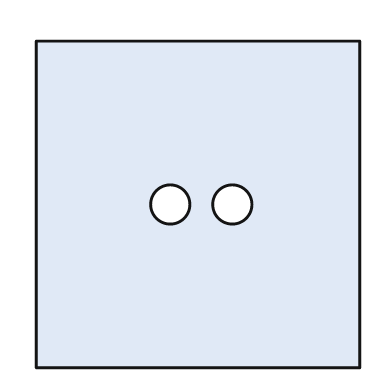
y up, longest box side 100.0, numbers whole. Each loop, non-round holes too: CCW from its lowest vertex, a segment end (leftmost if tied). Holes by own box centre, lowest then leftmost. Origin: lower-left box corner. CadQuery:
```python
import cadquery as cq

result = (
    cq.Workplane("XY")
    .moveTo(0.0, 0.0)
    .lineTo(99.0, 0.0)
    .lineTo(99.0, 100.0)
    .lineTo(0.0, 100.0)
    .close()
    .moveTo(41.0, 50.0)
    .circle(6.0)
    .moveTo(60.0, 50.0)
    .circle(6.0)
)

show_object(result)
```